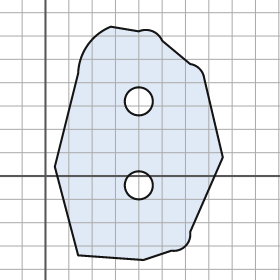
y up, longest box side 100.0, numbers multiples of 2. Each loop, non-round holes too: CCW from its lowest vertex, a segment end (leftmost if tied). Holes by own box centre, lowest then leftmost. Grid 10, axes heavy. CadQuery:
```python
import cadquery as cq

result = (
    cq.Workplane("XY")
    .moveTo(42.0, -36.0)
    .lineTo(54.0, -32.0)
    .threePointArc((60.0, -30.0), (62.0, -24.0))
    .lineTo(76.0, 8.0)
    .lineTo(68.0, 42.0)
    .threePointArc((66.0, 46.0), (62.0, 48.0))
    .lineTo(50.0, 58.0)
    .threePointArc((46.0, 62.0), (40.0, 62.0))
    .lineTo(28.0, 64.0)
    .threePointArc((18.0, 56.0), (14.0, 44.0))
    .lineTo(4.0, 4.0)
    .lineTo(14.0, -34.0)
    .close()
    .moveTo(40.0, -4.0)
    .circle(6.0)
    .moveTo(40.0, 32.0)
    .circle(6.0)
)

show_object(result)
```